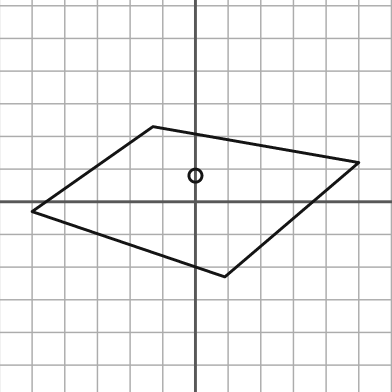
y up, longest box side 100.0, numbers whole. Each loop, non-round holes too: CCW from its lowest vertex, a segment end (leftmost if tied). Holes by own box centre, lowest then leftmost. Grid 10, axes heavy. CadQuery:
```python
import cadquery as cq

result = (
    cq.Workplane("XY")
    .moveTo(9.0, -23.0)
    .lineTo(50.0, 12.0)
    .lineTo(-13.0, 23.0)
    .lineTo(-50.0, -3.0)
    .close()
    .moveTo(0.0, 8.0)
    .circle(2.0)
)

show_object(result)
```